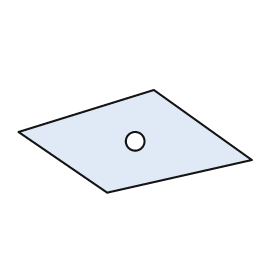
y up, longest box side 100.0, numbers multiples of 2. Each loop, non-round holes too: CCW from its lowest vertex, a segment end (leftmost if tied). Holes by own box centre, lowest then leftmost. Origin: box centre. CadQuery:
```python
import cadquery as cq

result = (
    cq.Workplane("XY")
    .moveTo(-12.0, -22.0)
    .lineTo(50.0, -8.0)
    .lineTo(8.0, 22.0)
    .lineTo(-50.0, 4.0)
    .close()
    .moveTo(0.0, 0.0)
    .circle(4.0)
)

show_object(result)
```